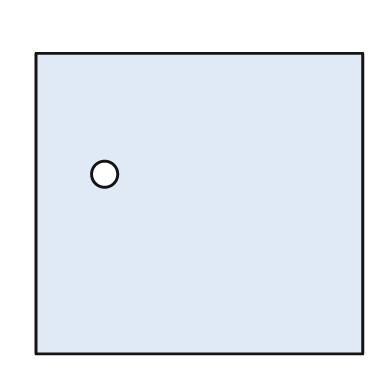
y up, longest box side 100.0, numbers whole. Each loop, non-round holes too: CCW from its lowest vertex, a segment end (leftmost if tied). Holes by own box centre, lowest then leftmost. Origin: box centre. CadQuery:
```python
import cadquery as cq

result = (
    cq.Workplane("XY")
    .moveTo(-50.0, -46.0)
    .lineTo(50.0, -46.0)
    .lineTo(50.0, 46.0)
    .lineTo(-50.0, 46.0)
    .close()
    .moveTo(-29.0, 9.0)
    .circle(4.0)
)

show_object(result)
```